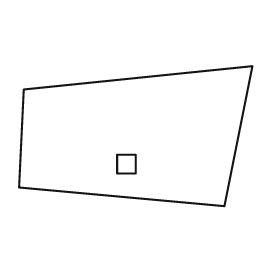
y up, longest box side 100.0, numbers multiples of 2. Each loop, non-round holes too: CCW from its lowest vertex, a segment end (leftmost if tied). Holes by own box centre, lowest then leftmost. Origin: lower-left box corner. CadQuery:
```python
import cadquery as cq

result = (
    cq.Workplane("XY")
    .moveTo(88.0, 0.0)
    .lineTo(100.0, 60.0)
    .lineTo(2.0, 50.0)
    .lineTo(0.0, 8.0)
    .close()
    .moveTo(42.0, 14.0)
    .lineTo(50.0, 14.0)
    .lineTo(50.0, 22.0)
    .lineTo(42.0, 22.0)
    .close()
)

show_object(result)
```